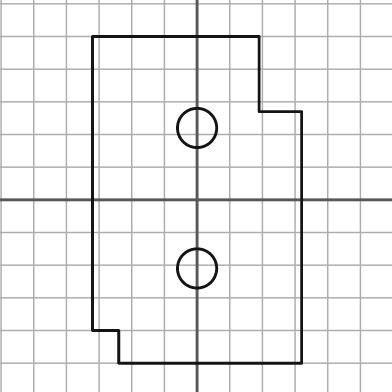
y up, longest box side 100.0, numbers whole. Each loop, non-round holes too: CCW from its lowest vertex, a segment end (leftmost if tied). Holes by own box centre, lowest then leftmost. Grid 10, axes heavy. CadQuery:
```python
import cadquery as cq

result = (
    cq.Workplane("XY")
    .moveTo(-24.0, -50.0)
    .lineTo(32.0, -50.0)
    .lineTo(32.0, 27.0)
    .lineTo(19.0, 27.0)
    .lineTo(19.0, 50.0)
    .lineTo(-32.0, 50.0)
    .lineTo(-32.0, -40.0)
    .lineTo(-24.0, -40.0)
    .close()
    .moveTo(0.0, -21.0)
    .circle(6.0)
    .moveTo(0.0, 22.0)
    .circle(6.0)
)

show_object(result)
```